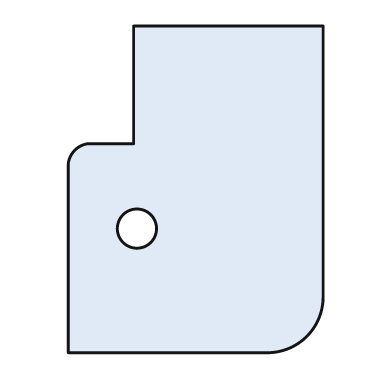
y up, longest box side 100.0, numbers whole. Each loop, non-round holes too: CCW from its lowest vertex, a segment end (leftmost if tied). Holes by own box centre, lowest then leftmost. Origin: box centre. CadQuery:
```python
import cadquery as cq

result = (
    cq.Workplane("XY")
    .moveTo(-39.0, -50.0)
    .lineTo(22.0, -50.0)
    .threePointArc((34.0, -45.0), (39.0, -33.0))
    .lineTo(39.0, 50.0)
    .lineTo(-19.0, 50.0)
    .lineTo(-19.0, 14.0)
    .lineTo(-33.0, 14.0)
    .threePointArc((-37.0, 12.0), (-39.0, 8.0))
    .close()
    .moveTo(-18.0, -12.0)
    .circle(6.0)
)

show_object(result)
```